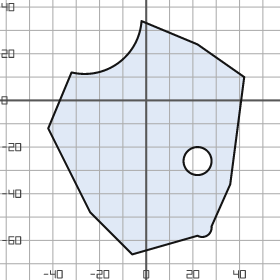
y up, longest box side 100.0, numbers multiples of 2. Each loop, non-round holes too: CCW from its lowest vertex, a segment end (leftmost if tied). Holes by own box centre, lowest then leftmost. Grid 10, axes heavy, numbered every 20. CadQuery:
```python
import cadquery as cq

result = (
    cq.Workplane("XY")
    .moveTo(-6.0, -66.0)
    .lineTo(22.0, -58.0)
    .threePointArc((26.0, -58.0), (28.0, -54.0))
    .lineTo(36.0, -36.0)
    .lineTo(42.0, 10.0)
    .lineTo(22.0, 24.0)
    .lineTo(-2.0, 34.0)
    .threePointArc((-12.0, 16.0), (-32.0, 12.0))
    .lineTo(-42.0, -12.0)
    .lineTo(-24.0, -48.0)
    .close()
    .moveTo(22.0, -26.0)
    .circle(6.0)
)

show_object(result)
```